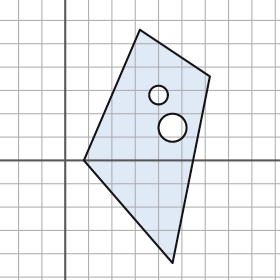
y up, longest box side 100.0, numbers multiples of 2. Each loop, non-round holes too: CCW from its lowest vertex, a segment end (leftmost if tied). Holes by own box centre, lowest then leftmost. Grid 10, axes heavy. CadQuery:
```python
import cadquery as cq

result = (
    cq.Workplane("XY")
    .moveTo(46.0, -44.0)
    .lineTo(62.0, 36.0)
    .lineTo(32.0, 56.0)
    .lineTo(8.0, 0.0)
    .close()
    .moveTo(46.0, 14.0)
    .circle(6.0)
    .moveTo(40.0, 28.0)
    .circle(4.0)
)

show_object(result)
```